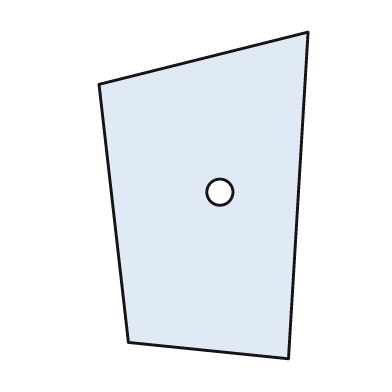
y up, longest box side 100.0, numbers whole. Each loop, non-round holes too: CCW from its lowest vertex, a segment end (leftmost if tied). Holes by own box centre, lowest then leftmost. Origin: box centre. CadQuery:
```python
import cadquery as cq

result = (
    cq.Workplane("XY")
    .moveTo(26.0, -50.0)
    .lineTo(32.0, 50.0)
    .lineTo(-32.0, 34.0)
    .lineTo(-23.0, -45.0)
    .close()
    .moveTo(5.0, 1.0)
    .circle(4.0)
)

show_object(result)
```